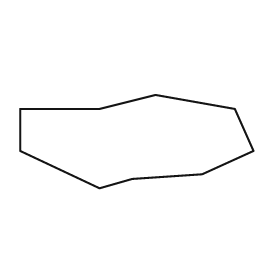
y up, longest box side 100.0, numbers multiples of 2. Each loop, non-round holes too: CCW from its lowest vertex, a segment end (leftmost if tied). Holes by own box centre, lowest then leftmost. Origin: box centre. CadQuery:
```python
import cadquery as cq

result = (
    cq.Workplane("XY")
    .moveTo(-16.0, -20.0)
    .lineTo(-2.0, -16.0)
    .lineTo(28.0, -14.0)
    .lineTo(50.0, -4.0)
    .lineTo(42.0, 14.0)
    .lineTo(8.0, 20.0)
    .lineTo(-16.0, 14.0)
    .lineTo(-50.0, 14.0)
    .lineTo(-50.0, -4.0)
    .close()
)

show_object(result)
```